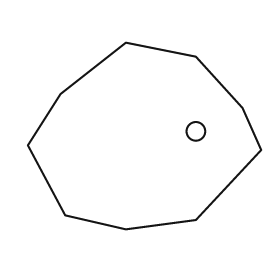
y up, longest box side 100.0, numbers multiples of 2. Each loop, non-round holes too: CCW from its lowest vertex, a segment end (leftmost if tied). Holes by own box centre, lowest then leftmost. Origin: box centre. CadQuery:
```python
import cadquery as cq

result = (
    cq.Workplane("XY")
    .moveTo(-8.0, -40.0)
    .lineTo(22.0, -36.0)
    .lineTo(50.0, -6.0)
    .lineTo(42.0, 12.0)
    .lineTo(22.0, 34.0)
    .lineTo(-8.0, 40.0)
    .lineTo(-36.0, 18.0)
    .lineTo(-50.0, -4.0)
    .lineTo(-34.0, -34.0)
    .close()
    .moveTo(22.0, 2.0)
    .circle(4.0)
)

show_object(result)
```